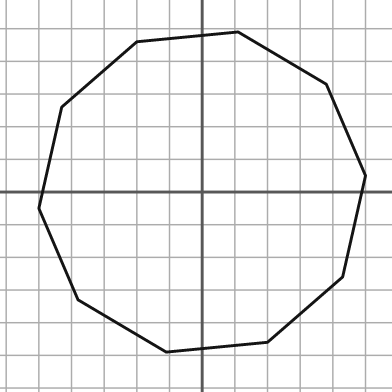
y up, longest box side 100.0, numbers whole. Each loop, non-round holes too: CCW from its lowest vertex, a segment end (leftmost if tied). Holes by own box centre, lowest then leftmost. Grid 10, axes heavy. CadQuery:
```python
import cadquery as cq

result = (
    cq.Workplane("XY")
    .moveTo(-11.0, -49.0)
    .lineTo(20.0, -46.0)
    .lineTo(43.0, -26.0)
    .lineTo(50.0, 5.0)
    .lineTo(38.0, 33.0)
    .lineTo(11.0, 49.0)
    .lineTo(-20.0, 46.0)
    .lineTo(-43.0, 26.0)
    .lineTo(-50.0, -5.0)
    .lineTo(-38.0, -33.0)
    .close()
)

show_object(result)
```